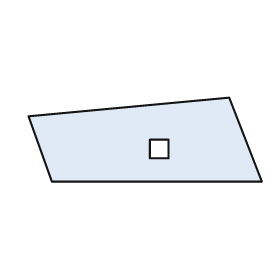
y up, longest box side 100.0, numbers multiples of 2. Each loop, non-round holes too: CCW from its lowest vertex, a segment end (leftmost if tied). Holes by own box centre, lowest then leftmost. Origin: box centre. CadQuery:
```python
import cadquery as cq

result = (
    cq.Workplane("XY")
    .moveTo(-40.0, -18.0)
    .lineTo(50.0, -18.0)
    .lineTo(36.0, 18.0)
    .lineTo(-50.0, 10.0)
    .close()
    .moveTo(2.0, -8.0)
    .lineTo(10.0, -8.0)
    .lineTo(10.0, 0.0)
    .lineTo(2.0, 0.0)
    .close()
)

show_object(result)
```